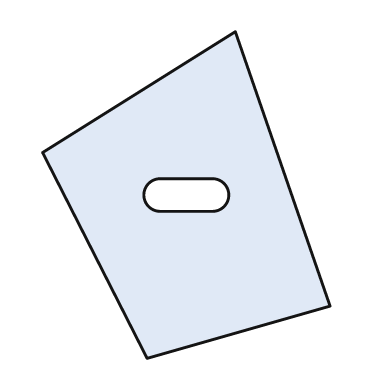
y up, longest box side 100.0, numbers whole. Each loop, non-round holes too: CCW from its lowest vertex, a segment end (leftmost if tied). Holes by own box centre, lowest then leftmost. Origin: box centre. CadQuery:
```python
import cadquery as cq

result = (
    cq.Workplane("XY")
    .moveTo(-12.0, -50.0)
    .lineTo(44.0, -34.0)
    .lineTo(15.0, 50.0)
    .lineTo(-44.0, 13.0)
    .close()
    .moveTo(-8.0, -5.0)
    .lineTo(8.0, -5.0)
    .threePointArc((13.0, 0.0), (8.0, 5.0))
    .lineTo(-8.0, 5.0)
    .threePointArc((-13.0, 0.0), (-8.0, -5.0))
    .close()
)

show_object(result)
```